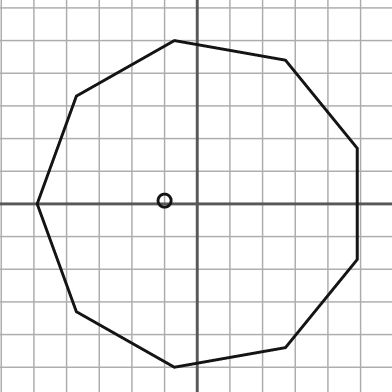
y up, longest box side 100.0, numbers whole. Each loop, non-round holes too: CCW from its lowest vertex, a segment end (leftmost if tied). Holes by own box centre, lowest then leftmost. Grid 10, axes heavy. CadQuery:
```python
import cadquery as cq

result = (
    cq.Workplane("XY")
    .moveTo(-7.0, -50.0)
    .lineTo(27.0, -44.0)
    .lineTo(49.0, -17.0)
    .lineTo(49.0, 17.0)
    .lineTo(27.0, 44.0)
    .lineTo(-7.0, 50.0)
    .lineTo(-37.0, 33.0)
    .lineTo(-49.0, 0.0)
    .lineTo(-37.0, -33.0)
    .close()
    .moveTo(-10.0, 1.0)
    .circle(2.0)
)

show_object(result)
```